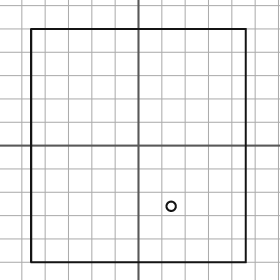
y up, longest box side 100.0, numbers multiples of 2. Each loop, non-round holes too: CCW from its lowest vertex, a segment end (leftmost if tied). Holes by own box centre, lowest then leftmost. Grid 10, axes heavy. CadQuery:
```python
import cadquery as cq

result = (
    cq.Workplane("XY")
    .moveTo(-46.0, -50.0)
    .lineTo(46.0, -50.0)
    .lineTo(46.0, 50.0)
    .lineTo(-46.0, 50.0)
    .close()
    .moveTo(14.0, -26.0)
    .circle(2.0)
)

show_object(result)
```